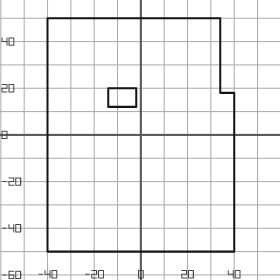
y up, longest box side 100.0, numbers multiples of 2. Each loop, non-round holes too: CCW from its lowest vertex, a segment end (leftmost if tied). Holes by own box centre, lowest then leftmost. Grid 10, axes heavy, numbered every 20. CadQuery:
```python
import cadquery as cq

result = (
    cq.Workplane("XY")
    .moveTo(-40.0, -50.0)
    .lineTo(40.0, -50.0)
    .lineTo(40.0, 18.0)
    .lineTo(34.0, 18.0)
    .lineTo(34.0, 50.0)
    .lineTo(-40.0, 50.0)
    .close()
    .moveTo(-14.0, 12.0)
    .lineTo(-2.0, 12.0)
    .lineTo(-2.0, 20.0)
    .lineTo(-14.0, 20.0)
    .close()
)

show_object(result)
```